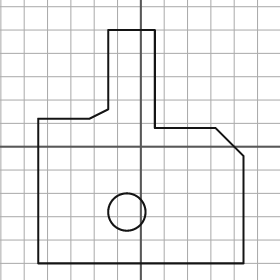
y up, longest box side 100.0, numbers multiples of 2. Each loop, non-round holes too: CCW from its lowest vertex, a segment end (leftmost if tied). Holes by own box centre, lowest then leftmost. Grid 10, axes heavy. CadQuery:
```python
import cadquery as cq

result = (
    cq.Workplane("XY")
    .moveTo(-44.0, -50.0)
    .lineTo(44.0, -50.0)
    .lineTo(44.0, -4.0)
    .lineTo(32.0, 8.0)
    .lineTo(6.0, 8.0)
    .lineTo(6.0, 50.0)
    .lineTo(-14.0, 50.0)
    .lineTo(-14.0, 16.0)
    .lineTo(-22.0, 12.0)
    .lineTo(-44.0, 12.0)
    .close()
    .moveTo(-6.0, -28.0)
    .circle(8.0)
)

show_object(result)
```